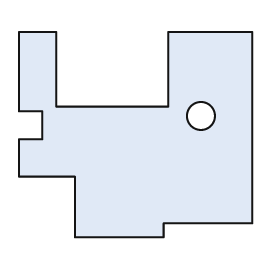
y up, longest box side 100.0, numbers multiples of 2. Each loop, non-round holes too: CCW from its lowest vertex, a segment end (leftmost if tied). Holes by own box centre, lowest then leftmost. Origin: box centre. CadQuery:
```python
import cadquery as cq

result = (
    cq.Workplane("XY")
    .moveTo(-26.0, -44.0)
    .lineTo(12.0, -44.0)
    .lineTo(12.0, -38.0)
    .lineTo(50.0, -38.0)
    .lineTo(50.0, 44.0)
    .lineTo(14.0, 44.0)
    .lineTo(14.0, 12.0)
    .lineTo(-34.0, 12.0)
    .lineTo(-34.0, 44.0)
    .lineTo(-50.0, 44.0)
    .lineTo(-50.0, 10.0)
    .lineTo(-40.0, 10.0)
    .lineTo(-40.0, -2.0)
    .lineTo(-50.0, -2.0)
    .lineTo(-50.0, -18.0)
    .lineTo(-26.0, -18.0)
    .close()
    .moveTo(28.0, 8.0)
    .circle(6.0)
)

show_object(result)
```